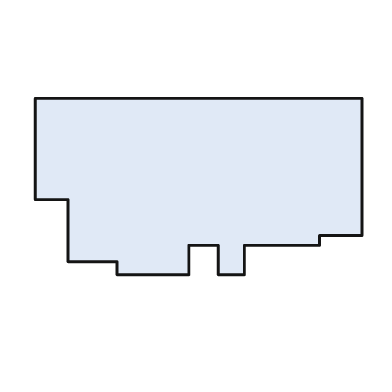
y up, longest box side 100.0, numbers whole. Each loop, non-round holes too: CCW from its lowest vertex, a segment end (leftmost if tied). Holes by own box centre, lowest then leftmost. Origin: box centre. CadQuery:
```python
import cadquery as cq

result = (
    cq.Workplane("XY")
    .moveTo(-25.0, -27.0)
    .lineTo(-3.0, -27.0)
    .lineTo(-3.0, -18.0)
    .lineTo(6.0, -18.0)
    .lineTo(6.0, -27.0)
    .lineTo(14.0, -27.0)
    .lineTo(14.0, -18.0)
    .lineTo(37.0, -18.0)
    .lineTo(37.0, -15.0)
    .lineTo(50.0, -15.0)
    .lineTo(50.0, 27.0)
    .lineTo(-50.0, 27.0)
    .lineTo(-50.0, -4.0)
    .lineTo(-40.0, -4.0)
    .lineTo(-40.0, -23.0)
    .lineTo(-25.0, -23.0)
    .close()
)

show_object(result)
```